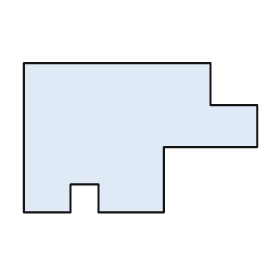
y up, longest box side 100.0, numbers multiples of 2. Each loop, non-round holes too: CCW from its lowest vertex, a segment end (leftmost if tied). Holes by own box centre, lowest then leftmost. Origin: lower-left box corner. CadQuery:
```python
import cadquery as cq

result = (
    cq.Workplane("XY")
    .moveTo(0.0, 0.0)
    .lineTo(20.0, 0.0)
    .lineTo(20.0, 12.0)
    .lineTo(32.0, 12.0)
    .lineTo(32.0, 0.0)
    .lineTo(60.0, 0.0)
    .lineTo(60.0, 28.0)
    .lineTo(100.0, 28.0)
    .lineTo(100.0, 46.0)
    .lineTo(80.0, 46.0)
    .lineTo(80.0, 64.0)
    .lineTo(0.0, 64.0)
    .close()
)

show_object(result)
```